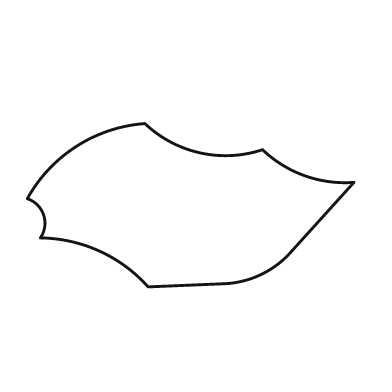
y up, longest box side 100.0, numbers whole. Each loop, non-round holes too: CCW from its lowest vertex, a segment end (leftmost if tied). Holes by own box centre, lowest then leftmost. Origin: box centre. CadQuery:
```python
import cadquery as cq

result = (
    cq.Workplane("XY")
    .moveTo(-13.0, -25.0)
    .lineTo(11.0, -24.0)
    .threePointArc((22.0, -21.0), (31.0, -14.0))
    .lineTo(50.0, 7.0)
    .threePointArc((35.0, 9.0), (22.0, 17.0))
    .threePointArc((3.0, 16.0), (-14.0, 25.0))
    .threePointArc((-35.0, 18.0), (-50.0, 2.0))
    .threePointArc((-45.0, -3.0), (-46.0, -10.0))
    .threePointArc((-28.0, -14.0), (-13.0, -25.0))
    .close()
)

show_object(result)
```